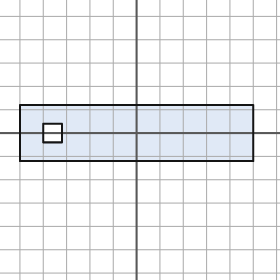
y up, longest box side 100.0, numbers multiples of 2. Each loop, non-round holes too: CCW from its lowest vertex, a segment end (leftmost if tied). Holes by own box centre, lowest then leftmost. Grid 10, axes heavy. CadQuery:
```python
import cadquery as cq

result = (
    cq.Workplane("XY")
    .moveTo(-50.0, -12.0)
    .lineTo(50.0, -12.0)
    .lineTo(50.0, 12.0)
    .lineTo(-50.0, 12.0)
    .close()
    .moveTo(-40.0, -4.0)
    .lineTo(-32.0, -4.0)
    .lineTo(-32.0, 4.0)
    .lineTo(-40.0, 4.0)
    .close()
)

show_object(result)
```